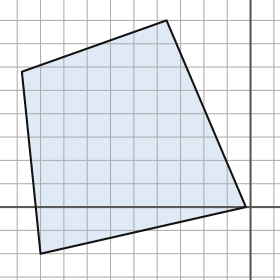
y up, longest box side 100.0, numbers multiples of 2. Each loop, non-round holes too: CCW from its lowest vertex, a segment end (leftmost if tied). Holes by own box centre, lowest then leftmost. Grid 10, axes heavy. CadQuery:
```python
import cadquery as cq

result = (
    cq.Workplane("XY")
    .moveTo(-90.0, -20.0)
    .lineTo(-2.0, 0.0)
    .lineTo(-36.0, 80.0)
    .lineTo(-98.0, 58.0)
    .close()
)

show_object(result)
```